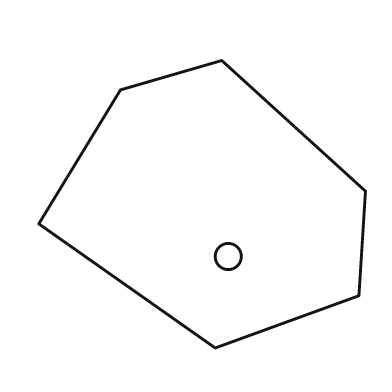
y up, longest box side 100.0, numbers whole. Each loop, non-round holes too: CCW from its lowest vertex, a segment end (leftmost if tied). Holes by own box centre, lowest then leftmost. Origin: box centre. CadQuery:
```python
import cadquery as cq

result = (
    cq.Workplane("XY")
    .moveTo(4.0, -44.0)
    .lineTo(48.0, -28.0)
    .lineTo(50.0, 4.0)
    .lineTo(6.0, 44.0)
    .lineTo(-25.0, 35.0)
    .lineTo(-50.0, -6.0)
    .close()
    .moveTo(8.0, -16.0)
    .circle(4.0)
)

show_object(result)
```